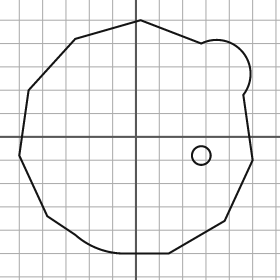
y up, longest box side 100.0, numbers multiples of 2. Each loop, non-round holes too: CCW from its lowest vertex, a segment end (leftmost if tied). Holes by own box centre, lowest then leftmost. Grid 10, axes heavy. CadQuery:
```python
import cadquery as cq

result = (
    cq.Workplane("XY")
    .moveTo(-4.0, -50.0)
    .lineTo(14.0, -50.0)
    .lineTo(38.0, -36.0)
    .lineTo(50.0, -10.0)
    .lineTo(46.0, 18.0)
    .threePointArc((46.0, 36.0), (28.0, 40.0))
    .lineTo(2.0, 50.0)
    .lineTo(-26.0, 42.0)
    .lineTo(-46.0, 20.0)
    .lineTo(-50.0, -8.0)
    .lineTo(-38.0, -34.0)
    .lineTo(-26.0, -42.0)
    .threePointArc((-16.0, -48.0), (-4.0, -50.0))
    .close()
    .moveTo(28.0, -8.0)
    .circle(4.0)
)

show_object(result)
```